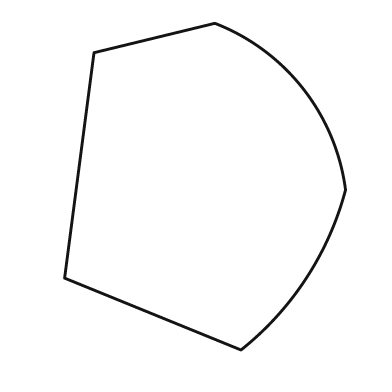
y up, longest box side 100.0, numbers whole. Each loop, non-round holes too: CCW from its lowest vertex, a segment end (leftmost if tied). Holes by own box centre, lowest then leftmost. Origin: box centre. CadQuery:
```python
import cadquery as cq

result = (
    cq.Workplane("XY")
    .moveTo(11.0, -50.0)
    .threePointArc((31.0, -28.0), (43.0, -1.0))
    .threePointArc((30.0, 30.0), (3.0, 50.0))
    .lineTo(-34.0, 41.0)
    .lineTo(-43.0, -28.0)
    .close()
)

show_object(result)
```